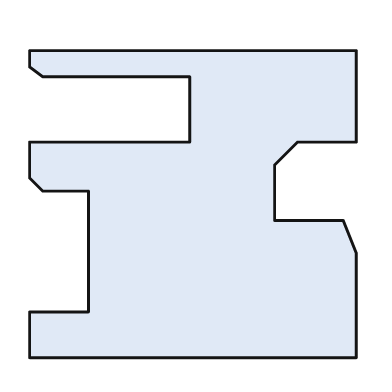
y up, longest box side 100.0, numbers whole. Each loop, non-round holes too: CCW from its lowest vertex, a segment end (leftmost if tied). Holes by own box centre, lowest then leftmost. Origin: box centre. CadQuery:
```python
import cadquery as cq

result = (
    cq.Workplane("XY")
    .moveTo(-50.0, -47.0)
    .lineTo(50.0, -47.0)
    .lineTo(50.0, -15.0)
    .lineTo(46.0, -5.0)
    .lineTo(25.0, -5.0)
    .lineTo(25.0, 12.0)
    .lineTo(32.0, 19.0)
    .lineTo(50.0, 19.0)
    .lineTo(50.0, 47.0)
    .lineTo(-50.0, 47.0)
    .lineTo(-50.0, 42.0)
    .lineTo(-46.0, 39.0)
    .lineTo(-1.0, 39.0)
    .lineTo(-1.0, 19.0)
    .lineTo(-50.0, 19.0)
    .lineTo(-50.0, 8.0)
    .lineTo(-46.0, 4.0)
    .lineTo(-32.0, 4.0)
    .lineTo(-32.0, -33.0)
    .lineTo(-50.0, -33.0)
    .close()
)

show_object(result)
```